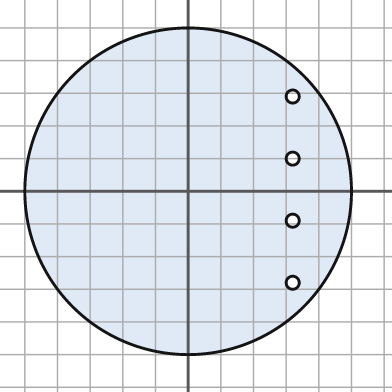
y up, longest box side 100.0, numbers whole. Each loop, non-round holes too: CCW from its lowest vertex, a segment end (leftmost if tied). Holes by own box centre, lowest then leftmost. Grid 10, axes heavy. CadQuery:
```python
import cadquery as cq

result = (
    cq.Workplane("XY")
    .moveTo(0.0, 0.0)
    .circle(50.0)
    .moveTo(32.0, -28.0)
    .circle(2.0)
    .moveTo(32.0, -9.0)
    .circle(2.0)
    .moveTo(32.0, 10.0)
    .circle(2.0)
    .moveTo(32.0, 29.0)
    .circle(2.0)
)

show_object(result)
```